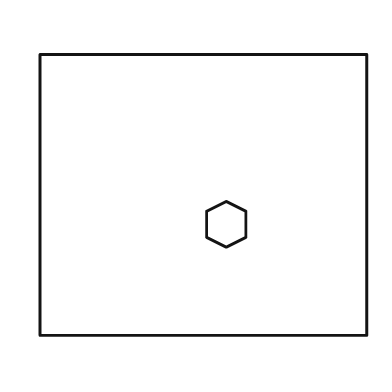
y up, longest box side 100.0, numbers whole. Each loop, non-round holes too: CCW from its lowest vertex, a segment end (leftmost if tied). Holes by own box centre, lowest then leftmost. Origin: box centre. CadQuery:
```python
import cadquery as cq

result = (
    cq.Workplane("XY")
    .moveTo(-50.0, -43.0)
    .lineTo(50.0, -43.0)
    .lineTo(50.0, 43.0)
    .lineTo(-50.0, 43.0)
    .close()
    .moveTo(7.0, -16.0)
    .lineTo(13.0, -13.0)
    .lineTo(13.0, -5.0)
    .lineTo(7.0, -2.0)
    .lineTo(1.0, -5.0)
    .lineTo(1.0, -13.0)
    .close()
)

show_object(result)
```